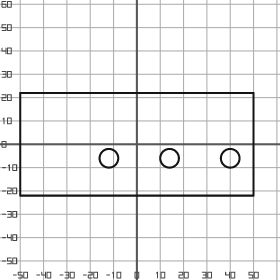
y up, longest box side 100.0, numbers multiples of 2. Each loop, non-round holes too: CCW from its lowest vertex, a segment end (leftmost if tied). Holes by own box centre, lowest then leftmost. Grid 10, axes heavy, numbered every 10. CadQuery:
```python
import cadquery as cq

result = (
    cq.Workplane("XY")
    .moveTo(-50.0, -22.0)
    .lineTo(50.0, -22.0)
    .lineTo(50.0, 22.0)
    .lineTo(-50.0, 22.0)
    .close()
    .moveTo(-12.0, -6.0)
    .circle(4.0)
    .moveTo(14.0, -6.0)
    .circle(4.0)
    .moveTo(40.0, -6.0)
    .circle(4.0)
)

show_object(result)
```